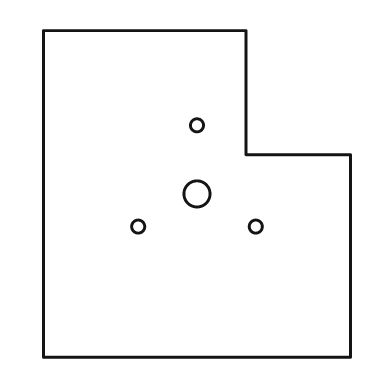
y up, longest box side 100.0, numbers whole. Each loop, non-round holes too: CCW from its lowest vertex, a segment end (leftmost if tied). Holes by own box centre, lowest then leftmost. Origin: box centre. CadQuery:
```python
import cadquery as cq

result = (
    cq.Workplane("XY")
    .moveTo(-47.0, -50.0)
    .lineTo(47.0, -50.0)
    .lineTo(47.0, 12.0)
    .lineTo(15.0, 12.0)
    .lineTo(15.0, 50.0)
    .lineTo(-47.0, 50.0)
    .close()
    .moveTo(-18.0, -10.0)
    .circle(2.0)
    .moveTo(18.0, -10.0)
    .circle(2.0)
    .moveTo(0.0, 0.0)
    .circle(4.0)
    .moveTo(0.0, 21.0)
    .circle(2.0)
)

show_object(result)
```